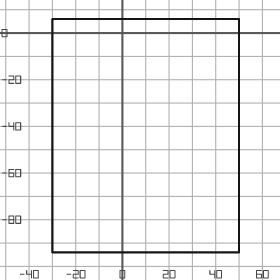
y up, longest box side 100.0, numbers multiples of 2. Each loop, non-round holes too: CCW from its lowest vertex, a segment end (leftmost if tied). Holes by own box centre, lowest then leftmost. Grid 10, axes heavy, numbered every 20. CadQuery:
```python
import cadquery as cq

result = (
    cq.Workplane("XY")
    .moveTo(-30.0, -94.0)
    .lineTo(50.0, -94.0)
    .lineTo(50.0, 6.0)
    .lineTo(-30.0, 6.0)
    .close()
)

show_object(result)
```